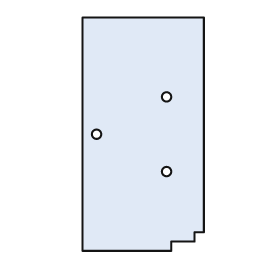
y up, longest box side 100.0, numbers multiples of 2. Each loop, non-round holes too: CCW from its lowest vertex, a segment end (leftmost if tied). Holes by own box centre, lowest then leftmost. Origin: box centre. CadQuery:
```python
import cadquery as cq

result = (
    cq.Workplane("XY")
    .moveTo(-26.0, -50.0)
    .lineTo(12.0, -50.0)
    .lineTo(12.0, -46.0)
    .lineTo(22.0, -46.0)
    .lineTo(22.0, -42.0)
    .lineTo(26.0, -42.0)
    .lineTo(26.0, 50.0)
    .lineTo(-26.0, 50.0)
    .close()
    .moveTo(10.0, -16.0)
    .circle(2.0)
    .moveTo(-20.0, 0.0)
    .circle(2.0)
    .moveTo(10.0, 16.0)
    .circle(2.0)
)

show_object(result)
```